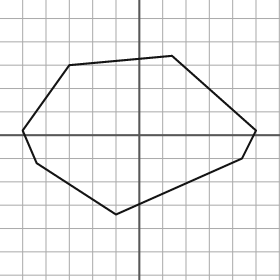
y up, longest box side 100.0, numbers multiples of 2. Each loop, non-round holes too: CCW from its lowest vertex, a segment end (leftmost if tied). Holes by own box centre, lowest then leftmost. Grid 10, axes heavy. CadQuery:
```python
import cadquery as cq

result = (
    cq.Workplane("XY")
    .moveTo(-10.0, -34.0)
    .lineTo(44.0, -10.0)
    .lineTo(50.0, 2.0)
    .lineTo(14.0, 34.0)
    .lineTo(-30.0, 30.0)
    .lineTo(-50.0, 2.0)
    .lineTo(-44.0, -12.0)
    .close()
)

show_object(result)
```